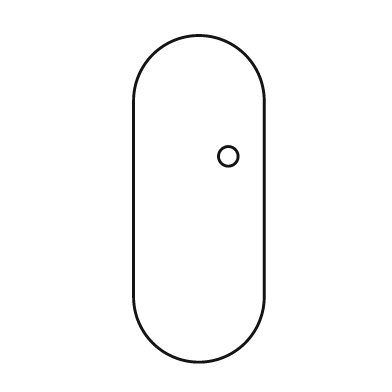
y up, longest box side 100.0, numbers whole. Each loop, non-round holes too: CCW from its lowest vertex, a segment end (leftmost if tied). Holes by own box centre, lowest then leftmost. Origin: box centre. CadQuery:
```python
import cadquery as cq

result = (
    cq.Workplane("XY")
    .moveTo(-20.0, -30.0)
    .threePointArc((0.0, -50.0), (20.0, -30.0))
    .lineTo(20.0, 30.0)
    .threePointArc((0.0, 50.0), (-20.0, 30.0))
    .close()
    .moveTo(9.0, 13.0)
    .circle(3.0)
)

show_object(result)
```